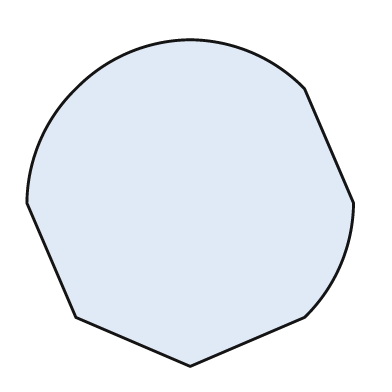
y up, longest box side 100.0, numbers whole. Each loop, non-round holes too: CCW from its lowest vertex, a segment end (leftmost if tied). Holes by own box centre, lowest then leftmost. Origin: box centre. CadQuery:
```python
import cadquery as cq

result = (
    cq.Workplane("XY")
    .moveTo(0.0, -50.0)
    .lineTo(35.0, -35.0)
    .threePointArc((46.0, -19.0), (50.0, 0.0))
    .lineTo(35.0, 35.0)
    .threePointArc((19.0, 46.0), (0.0, 50.0))
    .threePointArc((-19.0, 46.0), (-35.0, 35.0))
    .threePointArc((-46.0, 19.0), (-50.0, 0.0))
    .lineTo(-35.0, -35.0)
    .close()
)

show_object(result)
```